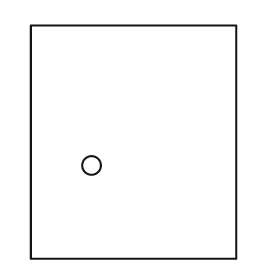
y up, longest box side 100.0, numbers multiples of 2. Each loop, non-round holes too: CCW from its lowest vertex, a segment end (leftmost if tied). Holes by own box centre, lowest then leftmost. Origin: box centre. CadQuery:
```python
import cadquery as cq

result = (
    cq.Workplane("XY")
    .moveTo(-44.0, -50.0)
    .lineTo(44.0, -50.0)
    .lineTo(44.0, 50.0)
    .lineTo(-44.0, 50.0)
    .close()
    .moveTo(-18.0, -10.0)
    .circle(4.0)
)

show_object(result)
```